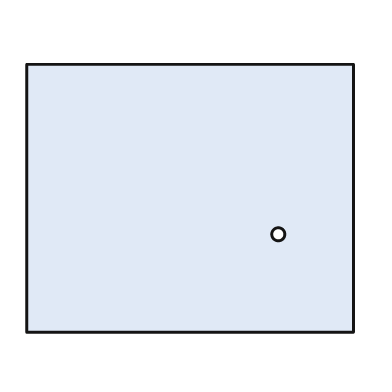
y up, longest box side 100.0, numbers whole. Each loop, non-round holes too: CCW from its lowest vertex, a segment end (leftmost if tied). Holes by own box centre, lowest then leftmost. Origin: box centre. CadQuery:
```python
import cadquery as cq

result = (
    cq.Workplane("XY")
    .moveTo(-50.0, -41.0)
    .lineTo(50.0, -41.0)
    .lineTo(50.0, 41.0)
    .lineTo(-50.0, 41.0)
    .close()
    .moveTo(27.0, -11.0)
    .circle(2.0)
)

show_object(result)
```